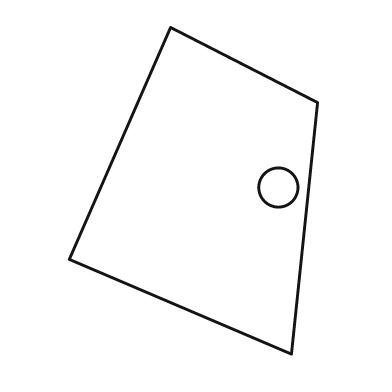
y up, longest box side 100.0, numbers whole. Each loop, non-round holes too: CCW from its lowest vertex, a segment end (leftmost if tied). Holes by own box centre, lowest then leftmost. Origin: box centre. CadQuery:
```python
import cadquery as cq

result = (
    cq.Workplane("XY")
    .moveTo(30.0, -50.0)
    .lineTo(38.0, 27.0)
    .lineTo(-7.0, 50.0)
    .lineTo(-38.0, -21.0)
    .close()
    .moveTo(26.0, 1.0)
    .circle(6.0)
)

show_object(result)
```